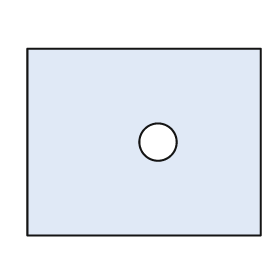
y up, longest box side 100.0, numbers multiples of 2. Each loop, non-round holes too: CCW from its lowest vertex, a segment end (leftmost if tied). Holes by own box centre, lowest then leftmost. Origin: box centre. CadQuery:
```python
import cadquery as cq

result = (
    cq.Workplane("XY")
    .moveTo(-50.0, -40.0)
    .lineTo(50.0, -40.0)
    .lineTo(50.0, 40.0)
    .lineTo(-50.0, 40.0)
    .close()
    .moveTo(6.0, 0.0)
    .circle(8.0)
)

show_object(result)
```